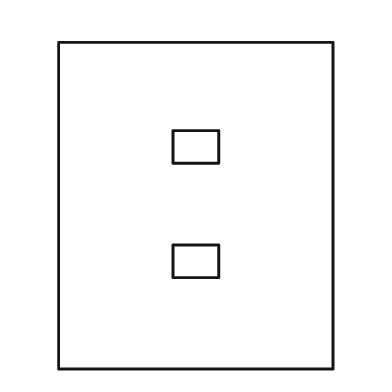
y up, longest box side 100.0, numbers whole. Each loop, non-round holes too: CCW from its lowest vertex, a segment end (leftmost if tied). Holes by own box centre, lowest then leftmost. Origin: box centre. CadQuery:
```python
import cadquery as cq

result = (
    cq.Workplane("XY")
    .moveTo(-42.0, -50.0)
    .lineTo(42.0, -50.0)
    .lineTo(42.0, 50.0)
    .lineTo(-42.0, 50.0)
    .close()
    .moveTo(-7.0, -22.0)
    .lineTo(7.0, -22.0)
    .lineTo(7.0, -12.0)
    .lineTo(-7.0, -12.0)
    .close()
    .moveTo(-7.0, 13.0)
    .lineTo(7.0, 13.0)
    .lineTo(7.0, 23.0)
    .lineTo(-7.0, 23.0)
    .close()
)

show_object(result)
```